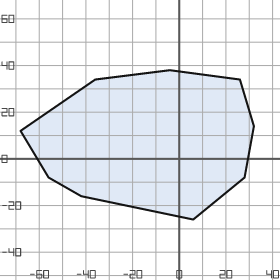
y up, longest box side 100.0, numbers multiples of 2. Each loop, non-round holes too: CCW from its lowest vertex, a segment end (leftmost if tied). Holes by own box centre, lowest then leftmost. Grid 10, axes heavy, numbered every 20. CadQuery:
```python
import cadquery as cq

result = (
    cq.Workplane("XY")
    .moveTo(6.0, -26.0)
    .lineTo(28.0, -8.0)
    .lineTo(32.0, 14.0)
    .lineTo(26.0, 34.0)
    .lineTo(-4.0, 38.0)
    .lineTo(-36.0, 34.0)
    .lineTo(-68.0, 12.0)
    .lineTo(-56.0, -8.0)
    .lineTo(-42.0, -16.0)
    .close()
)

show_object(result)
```